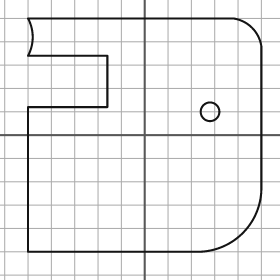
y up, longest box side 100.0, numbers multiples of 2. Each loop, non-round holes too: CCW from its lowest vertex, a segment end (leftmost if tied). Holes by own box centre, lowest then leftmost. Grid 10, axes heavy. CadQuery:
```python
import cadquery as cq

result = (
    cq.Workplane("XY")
    .moveTo(-50.0, -50.0)
    .lineTo(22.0, -50.0)
    .threePointArc((42.0, -42.0), (50.0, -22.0))
    .lineTo(50.0, 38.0)
    .threePointArc((46.0, 46.0), (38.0, 50.0))
    .lineTo(-50.0, 50.0)
    .threePointArc((-48.0, 42.0), (-50.0, 34.0))
    .lineTo(-16.0, 34.0)
    .lineTo(-16.0, 12.0)
    .lineTo(-50.0, 12.0)
    .close()
    .moveTo(28.0, 10.0)
    .circle(4.0)
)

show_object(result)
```